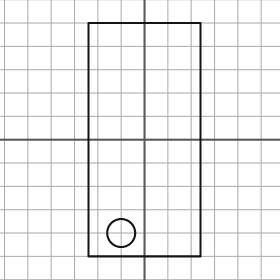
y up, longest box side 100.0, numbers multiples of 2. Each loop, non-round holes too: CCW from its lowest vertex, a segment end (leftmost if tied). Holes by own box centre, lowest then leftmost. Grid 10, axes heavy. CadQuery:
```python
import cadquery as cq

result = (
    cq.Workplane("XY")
    .moveTo(-24.0, -50.0)
    .lineTo(24.0, -50.0)
    .lineTo(24.0, 50.0)
    .lineTo(-24.0, 50.0)
    .close()
    .moveTo(-10.0, -40.0)
    .circle(6.0)
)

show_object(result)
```